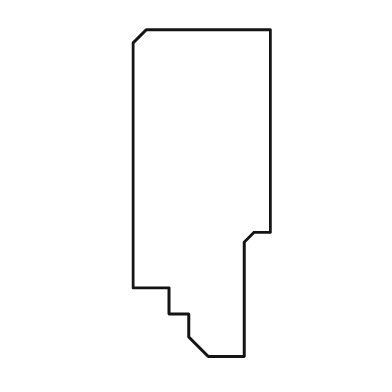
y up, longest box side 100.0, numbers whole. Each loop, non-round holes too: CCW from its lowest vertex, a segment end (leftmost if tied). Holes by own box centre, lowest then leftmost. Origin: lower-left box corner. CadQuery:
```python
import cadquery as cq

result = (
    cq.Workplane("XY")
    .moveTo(23.0, 0.0)
    .lineTo(34.0, 0.0)
    .lineTo(34.0, 35.0)
    .lineTo(37.0, 38.0)
    .lineTo(42.0, 38.0)
    .lineTo(42.0, 100.0)
    .lineTo(4.0, 100.0)
    .lineTo(0.0, 96.0)
    .lineTo(0.0, 21.0)
    .lineTo(11.0, 21.0)
    .lineTo(11.0, 13.0)
    .lineTo(17.0, 13.0)
    .lineTo(17.0, 6.0)
    .close()
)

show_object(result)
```